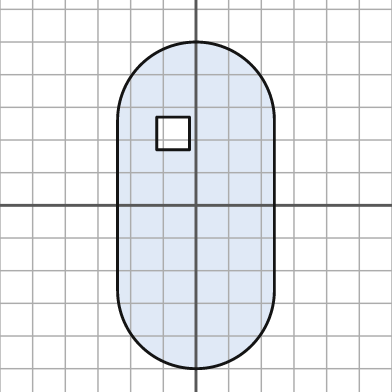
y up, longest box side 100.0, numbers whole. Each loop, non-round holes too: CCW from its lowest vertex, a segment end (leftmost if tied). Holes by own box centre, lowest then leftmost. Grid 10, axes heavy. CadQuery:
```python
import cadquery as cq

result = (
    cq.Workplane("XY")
    .moveTo(-24.0, -26.0)
    .threePointArc((0.0, -50.0), (24.0, -26.0))
    .lineTo(24.0, 26.0)
    .threePointArc((0.0, 50.0), (-24.0, 26.0))
    .close()
    .moveTo(-12.0, 17.0)
    .lineTo(-2.0, 17.0)
    .lineTo(-2.0, 27.0)
    .lineTo(-12.0, 27.0)
    .close()
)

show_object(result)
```